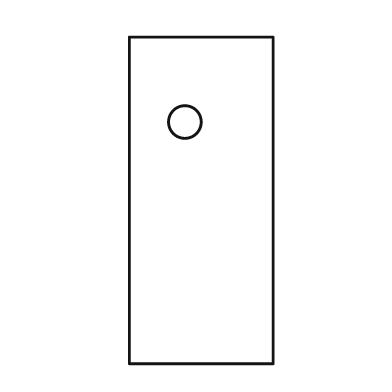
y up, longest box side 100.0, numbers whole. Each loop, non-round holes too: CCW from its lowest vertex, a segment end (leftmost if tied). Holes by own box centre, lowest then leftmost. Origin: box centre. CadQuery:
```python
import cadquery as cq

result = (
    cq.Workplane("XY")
    .moveTo(-22.0, -50.0)
    .lineTo(22.0, -50.0)
    .lineTo(22.0, 50.0)
    .lineTo(-22.0, 50.0)
    .close()
    .moveTo(-5.0, 24.0)
    .circle(5.0)
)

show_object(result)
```